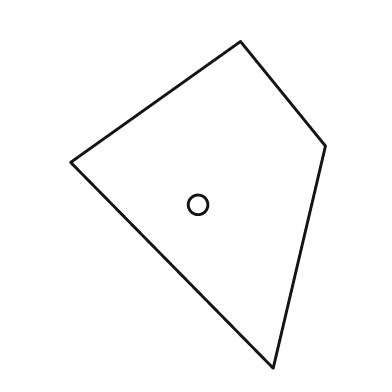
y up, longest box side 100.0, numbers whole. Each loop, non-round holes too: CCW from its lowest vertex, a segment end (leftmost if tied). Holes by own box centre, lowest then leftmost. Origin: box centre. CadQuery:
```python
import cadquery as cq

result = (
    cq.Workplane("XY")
    .moveTo(23.0, -50.0)
    .lineTo(39.0, 18.0)
    .lineTo(13.0, 50.0)
    .lineTo(-39.0, 13.0)
    .close()
    .moveTo(0.0, 0.0)
    .circle(3.0)
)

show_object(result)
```